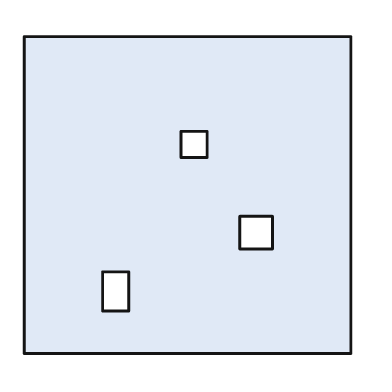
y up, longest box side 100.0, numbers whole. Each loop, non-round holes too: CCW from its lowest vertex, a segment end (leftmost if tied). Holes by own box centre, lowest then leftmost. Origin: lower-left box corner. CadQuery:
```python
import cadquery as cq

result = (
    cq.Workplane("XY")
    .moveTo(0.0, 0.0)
    .lineTo(100.0, 0.0)
    .lineTo(100.0, 97.0)
    .lineTo(0.0, 97.0)
    .close()
    .moveTo(24.0, 13.0)
    .lineTo(32.0, 13.0)
    .lineTo(32.0, 25.0)
    .lineTo(24.0, 25.0)
    .close()
    .moveTo(66.0, 32.0)
    .lineTo(76.0, 32.0)
    .lineTo(76.0, 42.0)
    .lineTo(66.0, 42.0)
    .close()
    .moveTo(48.0, 60.0)
    .lineTo(56.0, 60.0)
    .lineTo(56.0, 68.0)
    .lineTo(48.0, 68.0)
    .close()
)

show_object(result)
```